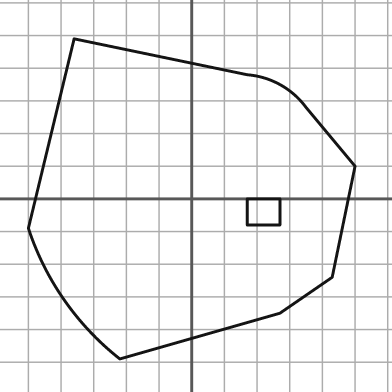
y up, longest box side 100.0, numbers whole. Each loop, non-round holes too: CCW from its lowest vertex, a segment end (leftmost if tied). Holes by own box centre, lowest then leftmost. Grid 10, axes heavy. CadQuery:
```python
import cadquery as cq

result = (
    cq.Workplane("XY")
    .moveTo(-22.0, -49.0)
    .lineTo(27.0, -35.0)
    .lineTo(43.0, -24.0)
    .lineTo(50.0, 10.0)
    .lineTo(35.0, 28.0)
    .threePointArc((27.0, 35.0), (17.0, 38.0))
    .lineTo(-36.0, 49.0)
    .lineTo(-50.0, -9.0)
    .threePointArc((-39.0, -31.0), (-22.0, -49.0))
    .close()
    .moveTo(17.0, -8.0)
    .lineTo(27.0, -8.0)
    .lineTo(27.0, 0.0)
    .lineTo(17.0, 0.0)
    .close()
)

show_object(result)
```